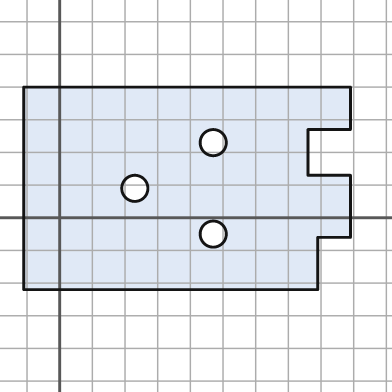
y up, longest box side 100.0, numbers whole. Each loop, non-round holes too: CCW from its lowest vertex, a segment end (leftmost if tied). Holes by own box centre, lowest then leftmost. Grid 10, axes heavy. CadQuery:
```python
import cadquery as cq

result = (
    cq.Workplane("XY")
    .moveTo(-11.0, -22.0)
    .lineTo(79.0, -22.0)
    .lineTo(79.0, -6.0)
    .lineTo(89.0, -6.0)
    .lineTo(89.0, 13.0)
    .lineTo(76.0, 13.0)
    .lineTo(76.0, 27.0)
    .lineTo(89.0, 27.0)
    .lineTo(89.0, 40.0)
    .lineTo(-11.0, 40.0)
    .close()
    .moveTo(47.0, -5.0)
    .circle(4.0)
    .moveTo(23.0, 9.0)
    .circle(4.0)
    .moveTo(47.0, 23.0)
    .circle(4.0)
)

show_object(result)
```